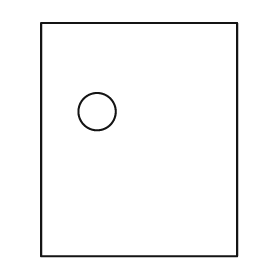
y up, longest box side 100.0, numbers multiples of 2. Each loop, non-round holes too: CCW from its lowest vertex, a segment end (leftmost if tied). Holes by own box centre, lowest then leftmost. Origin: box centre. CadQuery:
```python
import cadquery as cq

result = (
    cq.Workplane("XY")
    .moveTo(-42.0, -50.0)
    .lineTo(42.0, -50.0)
    .lineTo(42.0, 50.0)
    .lineTo(-42.0, 50.0)
    .close()
    .moveTo(-18.0, 12.0)
    .circle(8.0)
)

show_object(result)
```